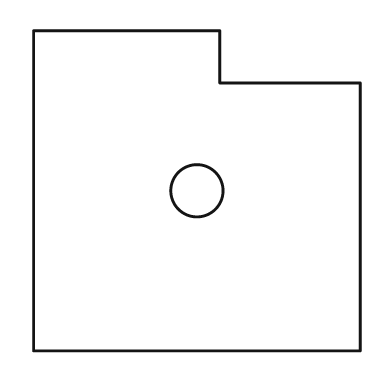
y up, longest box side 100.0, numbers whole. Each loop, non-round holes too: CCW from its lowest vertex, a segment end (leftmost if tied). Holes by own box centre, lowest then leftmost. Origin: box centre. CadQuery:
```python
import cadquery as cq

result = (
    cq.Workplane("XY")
    .moveTo(-50.0, -49.0)
    .lineTo(50.0, -49.0)
    .lineTo(50.0, 33.0)
    .lineTo(7.0, 33.0)
    .lineTo(7.0, 49.0)
    .lineTo(-50.0, 49.0)
    .close()
    .moveTo(0.0, 0.0)
    .circle(8.0)
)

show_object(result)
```